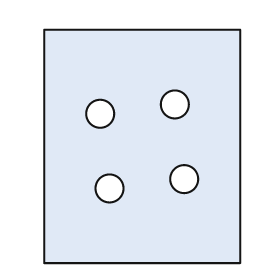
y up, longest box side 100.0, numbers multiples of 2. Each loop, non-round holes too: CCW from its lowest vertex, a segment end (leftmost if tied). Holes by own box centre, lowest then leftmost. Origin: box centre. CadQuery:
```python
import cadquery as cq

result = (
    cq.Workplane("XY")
    .moveTo(-42.0, -50.0)
    .lineTo(42.0, -50.0)
    .lineTo(42.0, 50.0)
    .lineTo(-42.0, 50.0)
    .close()
    .moveTo(-14.0, -18.0)
    .circle(6.0)
    .moveTo(18.0, -14.0)
    .circle(6.0)
    .moveTo(-18.0, 14.0)
    .circle(6.0)
    .moveTo(14.0, 18.0)
    .circle(6.0)
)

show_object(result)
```